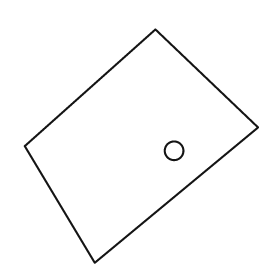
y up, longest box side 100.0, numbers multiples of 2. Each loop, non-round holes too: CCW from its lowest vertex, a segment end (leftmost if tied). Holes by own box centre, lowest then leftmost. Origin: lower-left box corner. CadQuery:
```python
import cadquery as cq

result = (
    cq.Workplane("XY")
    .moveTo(30.0, 0.0)
    .lineTo(100.0, 58.0)
    .lineTo(56.0, 100.0)
    .lineTo(0.0, 50.0)
    .close()
    .moveTo(64.0, 48.0)
    .circle(4.0)
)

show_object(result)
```